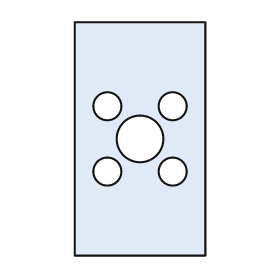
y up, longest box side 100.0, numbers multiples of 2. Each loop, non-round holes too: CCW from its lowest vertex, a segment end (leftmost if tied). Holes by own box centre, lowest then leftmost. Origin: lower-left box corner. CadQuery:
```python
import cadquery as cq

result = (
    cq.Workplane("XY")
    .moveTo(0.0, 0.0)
    .lineTo(56.0, 0.0)
    .lineTo(56.0, 100.0)
    .lineTo(0.0, 100.0)
    .close()
    .moveTo(14.0, 36.0)
    .circle(6.0)
    .moveTo(42.0, 36.0)
    .circle(6.0)
    .moveTo(28.0, 50.0)
    .circle(10.0)
    .moveTo(14.0, 64.0)
    .circle(6.0)
    .moveTo(42.0, 64.0)
    .circle(6.0)
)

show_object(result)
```